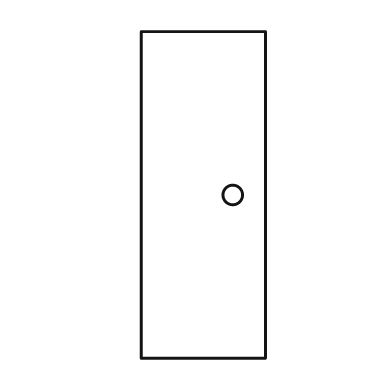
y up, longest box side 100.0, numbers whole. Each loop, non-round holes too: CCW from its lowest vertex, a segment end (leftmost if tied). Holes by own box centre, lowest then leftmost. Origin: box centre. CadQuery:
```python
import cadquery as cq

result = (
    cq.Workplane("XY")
    .moveTo(-19.0, -50.0)
    .lineTo(19.0, -50.0)
    .lineTo(19.0, 50.0)
    .lineTo(-19.0, 50.0)
    .close()
    .moveTo(9.0, 0.0)
    .circle(3.0)
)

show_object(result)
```